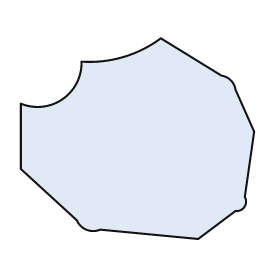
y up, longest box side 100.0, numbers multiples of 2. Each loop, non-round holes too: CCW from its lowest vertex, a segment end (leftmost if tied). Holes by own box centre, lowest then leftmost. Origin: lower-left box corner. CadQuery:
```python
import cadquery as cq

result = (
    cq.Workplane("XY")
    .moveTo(76.0, 0.0)
    .lineTo(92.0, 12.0)
    .threePointArc((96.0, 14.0), (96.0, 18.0))
    .lineTo(100.0, 46.0)
    .lineTo(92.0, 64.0)
    .threePointArc((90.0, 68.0), (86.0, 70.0))
    .lineTo(60.0, 86.0)
    .threePointArc((44.0, 78.0), (26.0, 76.0))
    .threePointArc((18.0, 60.0), (0.0, 58.0))
    .lineTo(0.0, 30.0)
    .lineTo(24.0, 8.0)
    .threePointArc((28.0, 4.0), (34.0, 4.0))
    .close()
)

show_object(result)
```